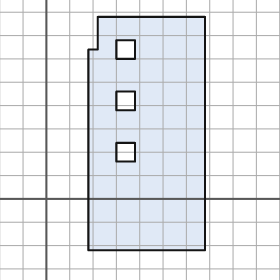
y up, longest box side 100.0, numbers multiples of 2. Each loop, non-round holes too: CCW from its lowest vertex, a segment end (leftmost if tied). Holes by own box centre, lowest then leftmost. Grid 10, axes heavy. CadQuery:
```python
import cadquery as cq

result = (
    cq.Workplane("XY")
    .moveTo(18.0, -22.0)
    .lineTo(68.0, -22.0)
    .lineTo(68.0, 78.0)
    .lineTo(22.0, 78.0)
    .lineTo(22.0, 64.0)
    .lineTo(18.0, 64.0)
    .close()
    .moveTo(30.0, 16.0)
    .lineTo(38.0, 16.0)
    .lineTo(38.0, 24.0)
    .lineTo(30.0, 24.0)
    .close()
    .moveTo(30.0, 38.0)
    .lineTo(38.0, 38.0)
    .lineTo(38.0, 46.0)
    .lineTo(30.0, 46.0)
    .close()
    .moveTo(30.0, 60.0)
    .lineTo(38.0, 60.0)
    .lineTo(38.0, 68.0)
    .lineTo(30.0, 68.0)
    .close()
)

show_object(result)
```